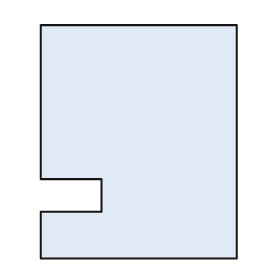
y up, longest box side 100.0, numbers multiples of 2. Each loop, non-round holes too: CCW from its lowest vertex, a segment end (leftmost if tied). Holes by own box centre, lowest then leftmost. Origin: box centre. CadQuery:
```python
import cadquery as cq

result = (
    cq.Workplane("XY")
    .moveTo(-42.0, -50.0)
    .lineTo(42.0, -50.0)
    .lineTo(42.0, 50.0)
    .lineTo(-42.0, 50.0)
    .lineTo(-42.0, -16.0)
    .lineTo(-16.0, -16.0)
    .lineTo(-16.0, -30.0)
    .lineTo(-42.0, -30.0)
    .close()
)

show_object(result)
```